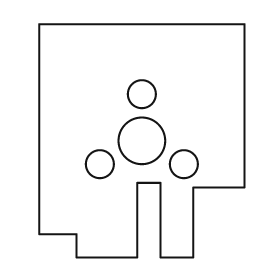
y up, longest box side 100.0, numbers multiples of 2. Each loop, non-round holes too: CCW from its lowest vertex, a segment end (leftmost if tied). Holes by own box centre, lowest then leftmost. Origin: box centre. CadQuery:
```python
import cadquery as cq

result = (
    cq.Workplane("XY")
    .moveTo(-28.0, -50.0)
    .lineTo(-2.0, -50.0)
    .lineTo(-2.0, -18.0)
    .lineTo(8.0, -18.0)
    .lineTo(8.0, -50.0)
    .lineTo(22.0, -50.0)
    .lineTo(22.0, -20.0)
    .lineTo(44.0, -20.0)
    .lineTo(44.0, 50.0)
    .lineTo(-44.0, 50.0)
    .lineTo(-44.0, -40.0)
    .lineTo(-28.0, -40.0)
    .close()
    .moveTo(-18.0, -10.0)
    .circle(6.0)
    .moveTo(18.0, -10.0)
    .circle(6.0)
    .moveTo(0.0, 0.0)
    .circle(10.0)
    .moveTo(0.0, 20.0)
    .circle(6.0)
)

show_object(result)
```